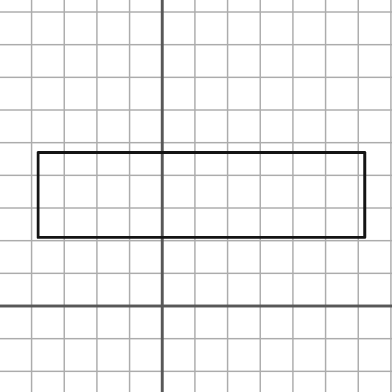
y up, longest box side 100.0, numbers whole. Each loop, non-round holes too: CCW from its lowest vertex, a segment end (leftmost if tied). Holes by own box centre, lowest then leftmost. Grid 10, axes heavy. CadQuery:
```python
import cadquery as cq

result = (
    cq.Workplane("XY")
    .moveTo(-38.0, 21.0)
    .lineTo(62.0, 21.0)
    .lineTo(62.0, 47.0)
    .lineTo(-38.0, 47.0)
    .close()
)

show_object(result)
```